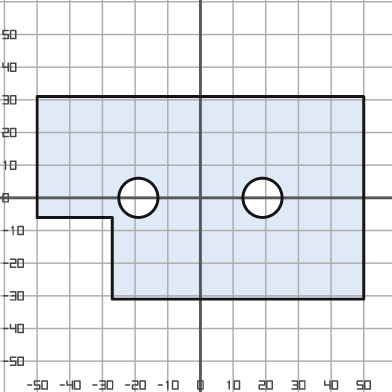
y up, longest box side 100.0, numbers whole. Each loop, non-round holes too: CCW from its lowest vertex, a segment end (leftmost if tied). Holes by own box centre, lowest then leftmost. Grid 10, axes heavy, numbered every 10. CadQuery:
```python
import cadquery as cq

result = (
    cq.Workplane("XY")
    .moveTo(-27.0, -31.0)
    .lineTo(50.0, -31.0)
    .lineTo(50.0, 31.0)
    .lineTo(-50.0, 31.0)
    .lineTo(-50.0, -6.0)
    .lineTo(-27.0, -6.0)
    .close()
    .moveTo(-19.0, 0.0)
    .circle(6.0)
    .moveTo(19.0, 0.0)
    .circle(6.0)
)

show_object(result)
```